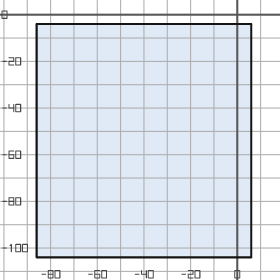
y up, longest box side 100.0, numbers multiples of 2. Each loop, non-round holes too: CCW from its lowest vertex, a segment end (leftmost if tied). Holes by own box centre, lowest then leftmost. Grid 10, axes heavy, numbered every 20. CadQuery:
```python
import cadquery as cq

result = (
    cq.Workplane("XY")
    .moveTo(-86.0, -104.0)
    .lineTo(6.0, -104.0)
    .lineTo(6.0, -4.0)
    .lineTo(-86.0, -4.0)
    .close()
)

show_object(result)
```